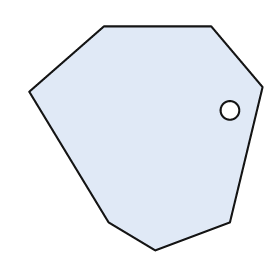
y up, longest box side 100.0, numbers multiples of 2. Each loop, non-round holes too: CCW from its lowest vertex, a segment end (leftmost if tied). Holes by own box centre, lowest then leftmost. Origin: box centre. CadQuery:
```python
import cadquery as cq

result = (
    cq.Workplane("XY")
    .moveTo(4.0, -48.0)
    .lineTo(36.0, -36.0)
    .lineTo(50.0, 22.0)
    .lineTo(28.0, 48.0)
    .lineTo(-18.0, 48.0)
    .lineTo(-50.0, 20.0)
    .lineTo(-16.0, -36.0)
    .close()
    .moveTo(36.0, 12.0)
    .circle(4.0)
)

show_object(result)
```